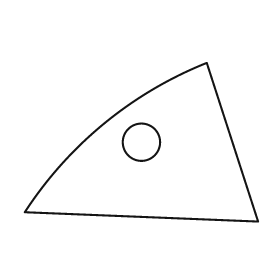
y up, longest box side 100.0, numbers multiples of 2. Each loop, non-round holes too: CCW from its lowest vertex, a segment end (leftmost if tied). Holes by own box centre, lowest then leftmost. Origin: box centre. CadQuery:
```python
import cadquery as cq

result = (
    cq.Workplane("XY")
    .moveTo(50.0, -34.0)
    .lineTo(28.0, 34.0)
    .threePointArc((-16.0, 8.0), (-50.0, -30.0))
    .close()
    .moveTo(0.0, 0.0)
    .circle(8.0)
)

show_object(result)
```